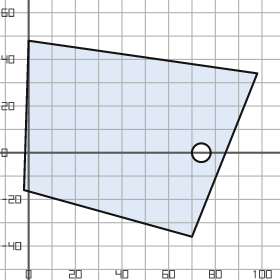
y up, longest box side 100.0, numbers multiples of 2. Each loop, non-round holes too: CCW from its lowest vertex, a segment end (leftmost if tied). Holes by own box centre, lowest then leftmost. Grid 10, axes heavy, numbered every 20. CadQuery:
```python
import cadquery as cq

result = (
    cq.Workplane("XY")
    .moveTo(70.0, -36.0)
    .lineTo(98.0, 34.0)
    .lineTo(0.0, 48.0)
    .lineTo(-2.0, -16.0)
    .close()
    .moveTo(74.0, 0.0)
    .circle(4.0)
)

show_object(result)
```